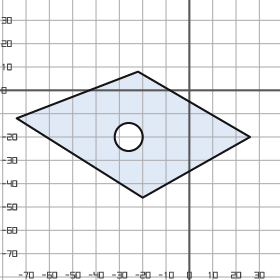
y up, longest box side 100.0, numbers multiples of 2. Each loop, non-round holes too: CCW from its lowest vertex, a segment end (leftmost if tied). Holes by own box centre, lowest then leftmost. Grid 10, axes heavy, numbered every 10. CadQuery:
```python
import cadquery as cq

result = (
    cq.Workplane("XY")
    .moveTo(-20.0, -46.0)
    .lineTo(26.0, -20.0)
    .lineTo(-22.0, 8.0)
    .lineTo(-74.0, -12.0)
    .close()
    .moveTo(-26.0, -20.0)
    .circle(6.0)
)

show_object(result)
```